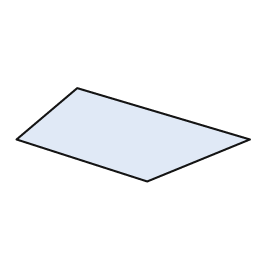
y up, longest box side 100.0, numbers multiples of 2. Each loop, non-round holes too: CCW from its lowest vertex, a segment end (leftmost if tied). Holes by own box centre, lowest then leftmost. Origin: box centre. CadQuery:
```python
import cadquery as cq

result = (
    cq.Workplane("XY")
    .moveTo(6.0, -20.0)
    .lineTo(50.0, -2.0)
    .lineTo(-24.0, 20.0)
    .lineTo(-50.0, -2.0)
    .close()
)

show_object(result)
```